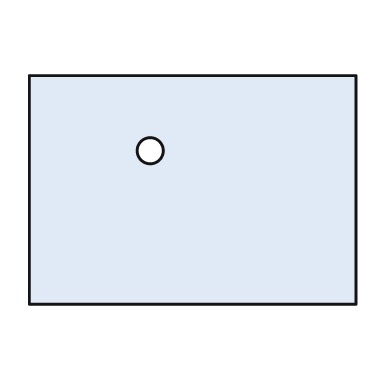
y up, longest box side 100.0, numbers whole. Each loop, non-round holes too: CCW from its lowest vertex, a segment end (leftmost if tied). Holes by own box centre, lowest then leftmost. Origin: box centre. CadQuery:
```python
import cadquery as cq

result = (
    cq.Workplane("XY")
    .moveTo(-50.0, -35.0)
    .lineTo(50.0, -35.0)
    .lineTo(50.0, 35.0)
    .lineTo(-50.0, 35.0)
    .close()
    .moveTo(-13.0, 12.0)
    .circle(4.0)
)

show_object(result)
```